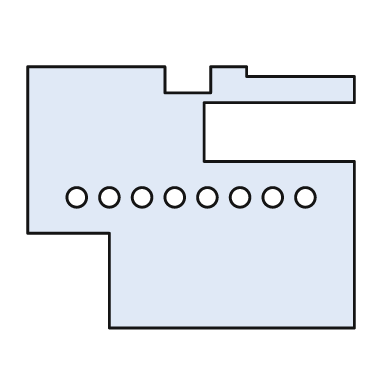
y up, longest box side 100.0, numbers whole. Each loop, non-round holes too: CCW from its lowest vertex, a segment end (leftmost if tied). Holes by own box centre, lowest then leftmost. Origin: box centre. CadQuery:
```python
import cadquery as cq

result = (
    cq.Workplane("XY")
    .moveTo(-25.0, -40.0)
    .lineTo(50.0, -40.0)
    .lineTo(50.0, 11.0)
    .lineTo(4.0, 11.0)
    .lineTo(4.0, 29.0)
    .lineTo(50.0, 29.0)
    .lineTo(50.0, 37.0)
    .lineTo(17.0, 37.0)
    .lineTo(17.0, 40.0)
    .lineTo(6.0, 40.0)
    .lineTo(6.0, 32.0)
    .lineTo(-8.0, 32.0)
    .lineTo(-8.0, 40.0)
    .lineTo(-50.0, 40.0)
    .lineTo(-50.0, -11.0)
    .lineTo(-25.0, -11.0)
    .close()
    .moveTo(-35.0, 0.0)
    .circle(3.0)
    .moveTo(-25.0, 0.0)
    .circle(3.0)
    .moveTo(-15.0, 0.0)
    .circle(3.0)
    .moveTo(-5.0, 0.0)
    .circle(3.0)
    .moveTo(5.0, 0.0)
    .circle(3.0)
    .moveTo(15.0, 0.0)
    .circle(3.0)
    .moveTo(25.0, 0.0)
    .circle(3.0)
    .moveTo(35.0, 0.0)
    .circle(3.0)
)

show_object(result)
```